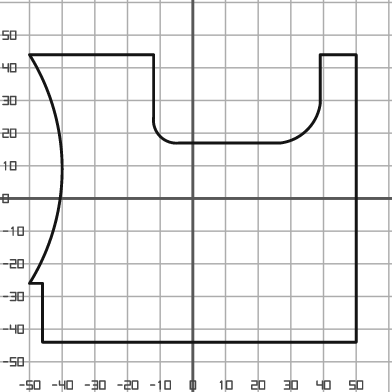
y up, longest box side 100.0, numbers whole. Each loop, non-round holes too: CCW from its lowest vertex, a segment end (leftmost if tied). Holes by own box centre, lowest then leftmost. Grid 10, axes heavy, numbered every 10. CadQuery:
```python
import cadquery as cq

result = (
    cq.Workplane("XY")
    .moveTo(-46.0, -44.0)
    .lineTo(50.0, -44.0)
    .lineTo(50.0, 44.0)
    .lineTo(39.0, 44.0)
    .lineTo(39.0, 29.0)
    .threePointArc((35.0, 21.0), (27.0, 17.0))
    .lineTo(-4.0, 17.0)
    .threePointArc((-10.0, 19.0), (-12.0, 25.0))
    .lineTo(-12.0, 44.0)
    .lineTo(-50.0, 44.0)
    .threePointArc((-40.0, 9.0), (-50.0, -26.0))
    .lineTo(-46.0, -26.0)
    .close()
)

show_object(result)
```